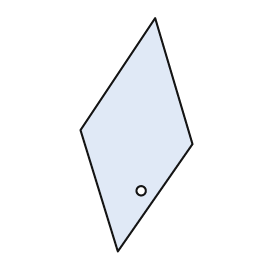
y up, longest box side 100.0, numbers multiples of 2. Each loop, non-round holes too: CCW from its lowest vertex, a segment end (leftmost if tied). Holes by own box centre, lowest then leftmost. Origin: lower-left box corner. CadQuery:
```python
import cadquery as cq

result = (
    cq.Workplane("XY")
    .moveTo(16.0, 0.0)
    .lineTo(48.0, 46.0)
    .lineTo(32.0, 100.0)
    .lineTo(0.0, 52.0)
    .close()
    .moveTo(26.0, 26.0)
    .circle(2.0)
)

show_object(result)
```